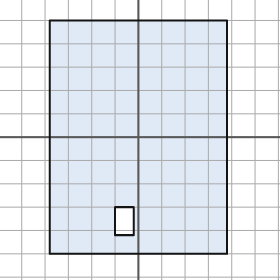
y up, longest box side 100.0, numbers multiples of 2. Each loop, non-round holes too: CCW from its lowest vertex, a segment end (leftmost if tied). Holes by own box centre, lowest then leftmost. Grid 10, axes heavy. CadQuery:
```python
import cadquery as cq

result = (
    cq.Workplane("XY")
    .moveTo(-38.0, -50.0)
    .lineTo(38.0, -50.0)
    .lineTo(38.0, 50.0)
    .lineTo(-38.0, 50.0)
    .close()
    .moveTo(-10.0, -42.0)
    .lineTo(-2.0, -42.0)
    .lineTo(-2.0, -30.0)
    .lineTo(-10.0, -30.0)
    .close()
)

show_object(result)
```